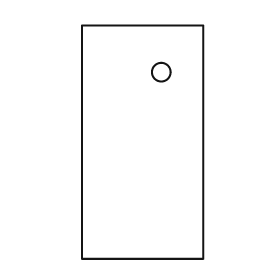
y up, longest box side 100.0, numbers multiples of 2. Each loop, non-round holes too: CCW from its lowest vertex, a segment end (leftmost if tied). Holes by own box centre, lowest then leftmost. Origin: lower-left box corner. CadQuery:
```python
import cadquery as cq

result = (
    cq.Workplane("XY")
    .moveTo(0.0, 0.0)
    .lineTo(52.0, 0.0)
    .lineTo(52.0, 100.0)
    .lineTo(0.0, 100.0)
    .close()
    .moveTo(34.0, 80.0)
    .circle(4.0)
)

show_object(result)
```